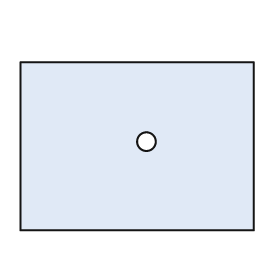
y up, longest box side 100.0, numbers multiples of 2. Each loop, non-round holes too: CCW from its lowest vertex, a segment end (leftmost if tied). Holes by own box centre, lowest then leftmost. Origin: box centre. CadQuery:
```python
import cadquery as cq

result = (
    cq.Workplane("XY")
    .moveTo(-50.0, -36.0)
    .lineTo(50.0, -36.0)
    .lineTo(50.0, 36.0)
    .lineTo(-50.0, 36.0)
    .close()
    .moveTo(4.0, 2.0)
    .circle(4.0)
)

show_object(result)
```